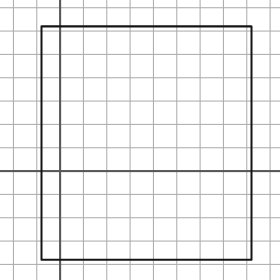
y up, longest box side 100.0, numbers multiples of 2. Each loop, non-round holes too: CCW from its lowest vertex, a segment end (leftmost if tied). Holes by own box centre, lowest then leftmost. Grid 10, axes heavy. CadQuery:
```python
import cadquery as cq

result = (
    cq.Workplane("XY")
    .moveTo(-8.0, -38.0)
    .lineTo(82.0, -38.0)
    .lineTo(82.0, 62.0)
    .lineTo(-8.0, 62.0)
    .close()
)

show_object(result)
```